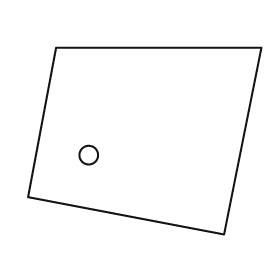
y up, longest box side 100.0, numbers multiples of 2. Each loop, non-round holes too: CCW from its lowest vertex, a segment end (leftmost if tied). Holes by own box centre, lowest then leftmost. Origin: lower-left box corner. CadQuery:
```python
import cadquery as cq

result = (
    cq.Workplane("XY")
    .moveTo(84.0, 0.0)
    .lineTo(100.0, 80.0)
    .lineTo(12.0, 80.0)
    .lineTo(0.0, 16.0)
    .close()
    .moveTo(26.0, 34.0)
    .circle(4.0)
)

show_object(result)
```